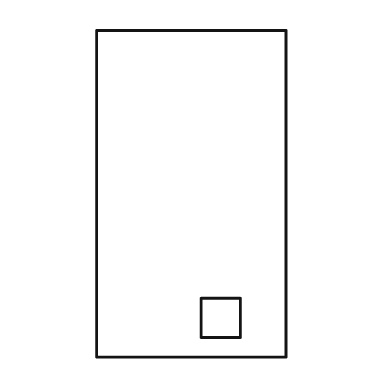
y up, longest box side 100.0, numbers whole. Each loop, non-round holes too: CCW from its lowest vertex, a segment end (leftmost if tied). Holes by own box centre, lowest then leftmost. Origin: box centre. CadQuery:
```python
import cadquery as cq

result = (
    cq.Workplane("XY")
    .moveTo(-29.0, -50.0)
    .lineTo(29.0, -50.0)
    .lineTo(29.0, 50.0)
    .lineTo(-29.0, 50.0)
    .close()
    .moveTo(3.0, -44.0)
    .lineTo(15.0, -44.0)
    .lineTo(15.0, -32.0)
    .lineTo(3.0, -32.0)
    .close()
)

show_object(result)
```